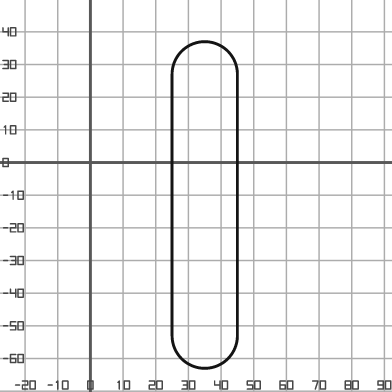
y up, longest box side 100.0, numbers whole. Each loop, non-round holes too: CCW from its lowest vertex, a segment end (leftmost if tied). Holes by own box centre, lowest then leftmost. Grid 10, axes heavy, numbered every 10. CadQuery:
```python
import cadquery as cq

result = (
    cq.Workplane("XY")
    .moveTo(25.0, -53.0)
    .threePointArc((35.0, -63.0), (45.0, -53.0))
    .lineTo(45.0, 27.0)
    .threePointArc((35.0, 37.0), (25.0, 27.0))
    .close()
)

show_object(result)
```